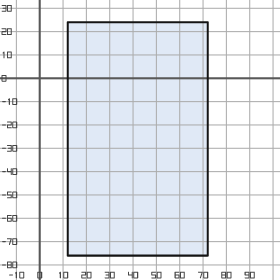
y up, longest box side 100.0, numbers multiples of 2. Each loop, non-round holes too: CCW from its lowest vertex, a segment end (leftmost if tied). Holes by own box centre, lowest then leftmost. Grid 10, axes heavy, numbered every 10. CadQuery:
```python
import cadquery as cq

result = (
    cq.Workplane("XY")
    .moveTo(12.0, -76.0)
    .lineTo(72.0, -76.0)
    .lineTo(72.0, 24.0)
    .lineTo(12.0, 24.0)
    .close()
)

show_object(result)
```